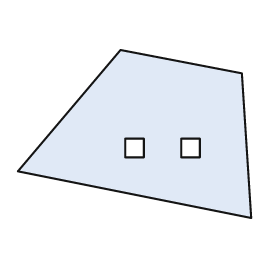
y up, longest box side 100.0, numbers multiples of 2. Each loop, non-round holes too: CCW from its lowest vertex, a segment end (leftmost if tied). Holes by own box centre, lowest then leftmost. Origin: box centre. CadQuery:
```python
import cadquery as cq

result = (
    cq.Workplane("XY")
    .moveTo(50.0, -36.0)
    .lineTo(46.0, 26.0)
    .lineTo(-6.0, 36.0)
    .lineTo(-50.0, -16.0)
    .close()
    .moveTo(-4.0, -10.0)
    .lineTo(4.0, -10.0)
    .lineTo(4.0, -2.0)
    .lineTo(-4.0, -2.0)
    .close()
    .moveTo(20.0, -10.0)
    .lineTo(28.0, -10.0)
    .lineTo(28.0, -2.0)
    .lineTo(20.0, -2.0)
    .close()
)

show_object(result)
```